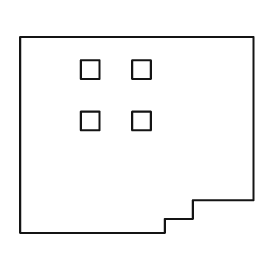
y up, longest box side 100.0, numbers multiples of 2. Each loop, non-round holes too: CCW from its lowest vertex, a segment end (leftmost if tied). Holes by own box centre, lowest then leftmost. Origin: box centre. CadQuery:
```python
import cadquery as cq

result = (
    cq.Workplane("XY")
    .moveTo(-50.0, -42.0)
    .lineTo(12.0, -42.0)
    .lineTo(12.0, -36.0)
    .lineTo(24.0, -36.0)
    .lineTo(24.0, -28.0)
    .lineTo(50.0, -28.0)
    .lineTo(50.0, 42.0)
    .lineTo(-50.0, 42.0)
    .close()
    .moveTo(-24.0, 2.0)
    .lineTo(-16.0, 2.0)
    .lineTo(-16.0, 10.0)
    .lineTo(-24.0, 10.0)
    .close()
    .moveTo(-2.0, 2.0)
    .lineTo(6.0, 2.0)
    .lineTo(6.0, 10.0)
    .lineTo(-2.0, 10.0)
    .close()
    .moveTo(-24.0, 24.0)
    .lineTo(-16.0, 24.0)
    .lineTo(-16.0, 32.0)
    .lineTo(-24.0, 32.0)
    .close()
    .moveTo(-2.0, 24.0)
    .lineTo(6.0, 24.0)
    .lineTo(6.0, 32.0)
    .lineTo(-2.0, 32.0)
    .close()
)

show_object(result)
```